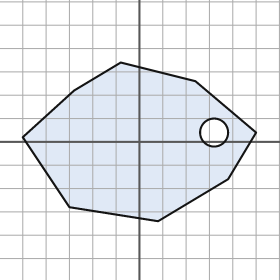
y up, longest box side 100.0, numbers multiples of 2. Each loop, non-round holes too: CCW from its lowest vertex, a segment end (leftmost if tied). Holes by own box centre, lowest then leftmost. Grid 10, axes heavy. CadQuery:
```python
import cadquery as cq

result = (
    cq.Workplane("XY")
    .moveTo(8.0, -34.0)
    .lineTo(38.0, -16.0)
    .lineTo(50.0, 4.0)
    .lineTo(24.0, 26.0)
    .lineTo(-8.0, 34.0)
    .lineTo(-28.0, 22.0)
    .lineTo(-50.0, 2.0)
    .lineTo(-30.0, -28.0)
    .close()
    .moveTo(32.0, 4.0)
    .circle(6.0)
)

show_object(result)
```